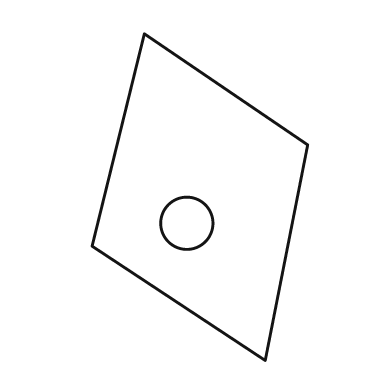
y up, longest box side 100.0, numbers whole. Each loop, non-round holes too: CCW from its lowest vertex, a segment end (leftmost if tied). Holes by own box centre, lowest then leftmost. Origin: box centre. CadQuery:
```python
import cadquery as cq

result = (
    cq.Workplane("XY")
    .moveTo(20.0, -50.0)
    .lineTo(33.0, 16.0)
    .lineTo(-17.0, 50.0)
    .lineTo(-33.0, -15.0)
    .close()
    .moveTo(-4.0, -8.0)
    .circle(8.0)
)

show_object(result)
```